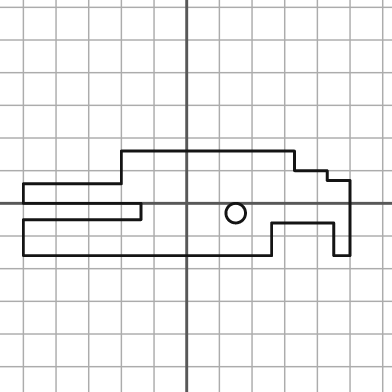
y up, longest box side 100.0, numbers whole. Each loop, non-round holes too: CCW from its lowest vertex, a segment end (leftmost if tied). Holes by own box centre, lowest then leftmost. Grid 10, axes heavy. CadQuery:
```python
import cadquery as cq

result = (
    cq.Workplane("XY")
    .moveTo(-50.0, -16.0)
    .lineTo(26.0, -16.0)
    .lineTo(26.0, -6.0)
    .lineTo(45.0, -6.0)
    .lineTo(45.0, -16.0)
    .lineTo(50.0, -16.0)
    .lineTo(50.0, 7.0)
    .lineTo(43.0, 7.0)
    .lineTo(43.0, 10.0)
    .lineTo(33.0, 10.0)
    .lineTo(33.0, 16.0)
    .lineTo(-20.0, 16.0)
    .lineTo(-20.0, 6.0)
    .lineTo(-50.0, 6.0)
    .lineTo(-50.0, 0.0)
    .lineTo(-14.0, 0.0)
    .lineTo(-14.0, -5.0)
    .lineTo(-50.0, -5.0)
    .close()
    .moveTo(15.0, -3.0)
    .circle(3.0)
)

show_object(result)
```